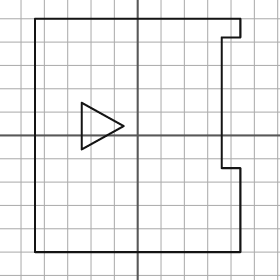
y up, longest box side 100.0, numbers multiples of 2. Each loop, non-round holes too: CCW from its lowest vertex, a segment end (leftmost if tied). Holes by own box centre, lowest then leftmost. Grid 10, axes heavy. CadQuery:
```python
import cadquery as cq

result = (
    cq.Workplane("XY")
    .moveTo(-44.0, -50.0)
    .lineTo(44.0, -50.0)
    .lineTo(44.0, -14.0)
    .lineTo(36.0, -14.0)
    .lineTo(36.0, 42.0)
    .lineTo(44.0, 42.0)
    .lineTo(44.0, 50.0)
    .lineTo(-44.0, 50.0)
    .close()
    .moveTo(-24.0, -6.0)
    .lineTo(-6.0, 4.0)
    .lineTo(-24.0, 14.0)
    .close()
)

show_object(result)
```